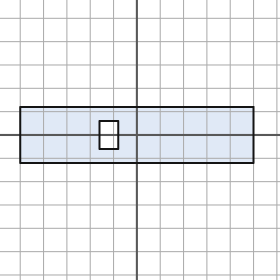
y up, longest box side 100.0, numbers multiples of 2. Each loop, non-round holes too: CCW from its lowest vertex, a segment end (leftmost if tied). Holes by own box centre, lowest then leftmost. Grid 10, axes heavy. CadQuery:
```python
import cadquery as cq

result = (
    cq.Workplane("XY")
    .moveTo(-50.0, -12.0)
    .lineTo(50.0, -12.0)
    .lineTo(50.0, 12.0)
    .lineTo(-50.0, 12.0)
    .close()
    .moveTo(-16.0, -6.0)
    .lineTo(-8.0, -6.0)
    .lineTo(-8.0, 6.0)
    .lineTo(-16.0, 6.0)
    .close()
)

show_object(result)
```